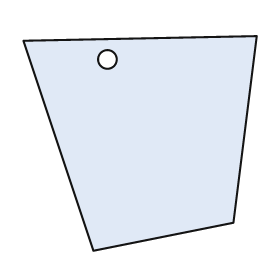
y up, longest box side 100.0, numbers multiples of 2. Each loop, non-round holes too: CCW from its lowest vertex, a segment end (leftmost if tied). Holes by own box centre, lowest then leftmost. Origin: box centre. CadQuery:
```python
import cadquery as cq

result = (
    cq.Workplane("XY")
    .moveTo(-20.0, -46.0)
    .lineTo(40.0, -34.0)
    .lineTo(50.0, 46.0)
    .lineTo(-50.0, 44.0)
    .close()
    .moveTo(-14.0, 36.0)
    .circle(4.0)
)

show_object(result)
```